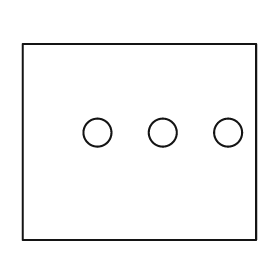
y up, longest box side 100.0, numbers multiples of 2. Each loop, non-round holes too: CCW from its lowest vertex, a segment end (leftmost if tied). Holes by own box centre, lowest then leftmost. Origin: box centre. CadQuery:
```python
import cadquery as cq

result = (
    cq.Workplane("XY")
    .moveTo(-50.0, -42.0)
    .lineTo(50.0, -42.0)
    .lineTo(50.0, 42.0)
    .lineTo(-50.0, 42.0)
    .close()
    .moveTo(-18.0, 4.0)
    .circle(6.0)
    .moveTo(10.0, 4.0)
    .circle(6.0)
    .moveTo(38.0, 4.0)
    .circle(6.0)
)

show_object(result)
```